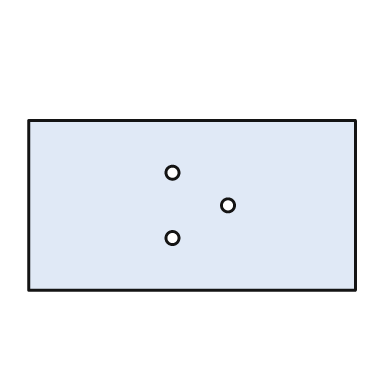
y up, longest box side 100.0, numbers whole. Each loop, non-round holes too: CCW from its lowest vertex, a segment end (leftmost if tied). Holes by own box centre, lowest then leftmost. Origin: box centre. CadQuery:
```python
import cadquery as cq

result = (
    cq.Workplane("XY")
    .moveTo(-50.0, -26.0)
    .lineTo(50.0, -26.0)
    .lineTo(50.0, 26.0)
    .lineTo(-50.0, 26.0)
    .close()
    .moveTo(-6.0, -10.0)
    .circle(2.0)
    .moveTo(11.0, 0.0)
    .circle(2.0)
    .moveTo(-6.0, 10.0)
    .circle(2.0)
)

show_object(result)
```